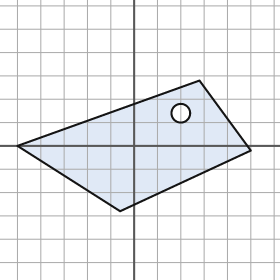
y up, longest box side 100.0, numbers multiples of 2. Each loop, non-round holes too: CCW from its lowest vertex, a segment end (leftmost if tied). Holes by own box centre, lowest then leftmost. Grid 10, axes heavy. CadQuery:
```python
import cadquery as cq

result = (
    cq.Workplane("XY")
    .moveTo(-6.0, -28.0)
    .lineTo(50.0, -2.0)
    .lineTo(28.0, 28.0)
    .lineTo(-50.0, 0.0)
    .close()
    .moveTo(20.0, 14.0)
    .circle(4.0)
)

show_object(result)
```